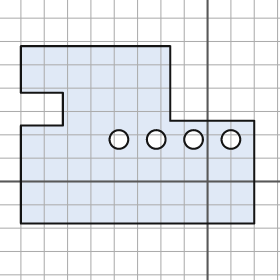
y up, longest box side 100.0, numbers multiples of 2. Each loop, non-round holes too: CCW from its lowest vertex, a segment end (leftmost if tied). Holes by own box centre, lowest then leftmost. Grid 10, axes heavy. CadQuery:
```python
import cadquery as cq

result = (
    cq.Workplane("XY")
    .moveTo(-80.0, -18.0)
    .lineTo(20.0, -18.0)
    .lineTo(20.0, 26.0)
    .lineTo(-16.0, 26.0)
    .lineTo(-16.0, 58.0)
    .lineTo(-80.0, 58.0)
    .lineTo(-80.0, 38.0)
    .lineTo(-62.0, 38.0)
    .lineTo(-62.0, 24.0)
    .lineTo(-80.0, 24.0)
    .close()
    .moveTo(-38.0, 18.0)
    .circle(4.0)
    .moveTo(-22.0, 18.0)
    .circle(4.0)
    .moveTo(-6.0, 18.0)
    .circle(4.0)
    .moveTo(10.0, 18.0)
    .circle(4.0)
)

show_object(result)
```